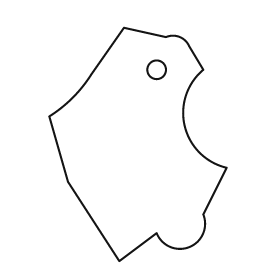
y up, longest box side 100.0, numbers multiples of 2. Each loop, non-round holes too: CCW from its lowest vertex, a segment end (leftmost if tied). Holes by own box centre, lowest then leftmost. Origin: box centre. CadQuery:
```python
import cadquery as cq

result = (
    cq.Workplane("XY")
    .moveTo(-8.0, -50.0)
    .lineTo(8.0, -38.0)
    .threePointArc((22.0, -44.0), (28.0, -30.0))
    .lineTo(38.0, -10.0)
    .threePointArc((20.0, 8.0), (28.0, 32.0))
    .lineTo(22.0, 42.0)
    .threePointArc((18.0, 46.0), (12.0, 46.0))
    .lineTo(-6.0, 50.0)
    .lineTo(-20.0, 30.0)
    .threePointArc((-28.0, 20.0), (-38.0, 12.0))
    .lineTo(-30.0, -16.0)
    .close()
    .moveTo(8.0, 32.0)
    .circle(4.0)
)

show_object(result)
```